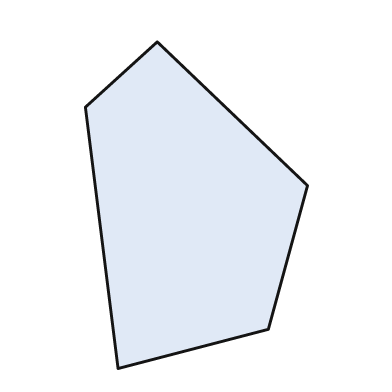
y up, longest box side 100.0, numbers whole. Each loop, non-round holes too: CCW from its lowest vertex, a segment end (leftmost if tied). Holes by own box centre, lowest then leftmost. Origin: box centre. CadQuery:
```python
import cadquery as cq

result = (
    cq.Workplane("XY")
    .moveTo(-24.0, -50.0)
    .lineTo(22.0, -38.0)
    .lineTo(34.0, 6.0)
    .lineTo(-12.0, 50.0)
    .lineTo(-34.0, 30.0)
    .close()
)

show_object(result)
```